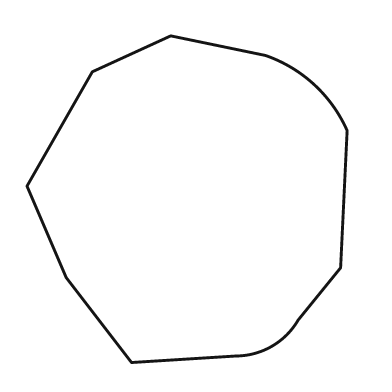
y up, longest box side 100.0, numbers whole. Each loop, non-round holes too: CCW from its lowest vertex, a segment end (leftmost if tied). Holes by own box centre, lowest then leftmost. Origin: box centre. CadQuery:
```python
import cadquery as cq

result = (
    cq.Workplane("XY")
    .moveTo(-17.0, -50.0)
    .lineTo(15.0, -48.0)
    .threePointArc((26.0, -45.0), (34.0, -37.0))
    .lineTo(47.0, -21.0)
    .lineTo(49.0, 21.0)
    .threePointArc((39.0, 35.0), (24.0, 44.0))
    .lineTo(-5.0, 50.0)
    .lineTo(-29.0, 39.0)
    .lineTo(-49.0, 4.0)
    .lineTo(-37.0, -24.0)
    .close()
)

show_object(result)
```